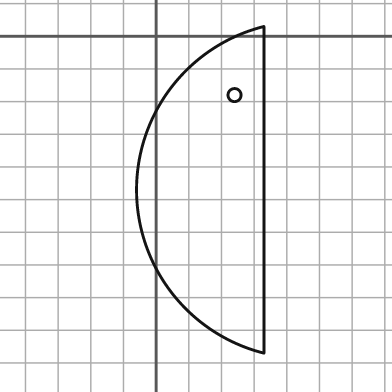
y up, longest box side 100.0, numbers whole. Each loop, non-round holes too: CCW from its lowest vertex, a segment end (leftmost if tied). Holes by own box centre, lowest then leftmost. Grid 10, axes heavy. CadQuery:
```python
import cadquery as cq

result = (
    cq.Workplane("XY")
    .moveTo(33.0, -97.0)
    .lineTo(33.0, 3.0)
    .threePointArc((-6.0, -47.0), (33.0, -97.0))
    .close()
    .moveTo(24.0, -18.0)
    .circle(2.0)
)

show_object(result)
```